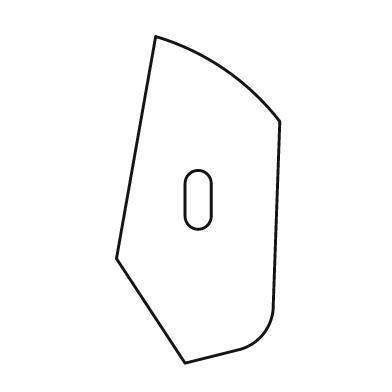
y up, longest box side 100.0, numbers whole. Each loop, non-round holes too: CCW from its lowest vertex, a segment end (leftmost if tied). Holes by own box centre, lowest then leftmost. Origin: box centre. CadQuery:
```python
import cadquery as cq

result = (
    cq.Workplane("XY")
    .moveTo(-4.0, -50.0)
    .lineTo(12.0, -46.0)
    .threePointArc((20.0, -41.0), (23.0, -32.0))
    .lineTo(25.0, 24.0)
    .threePointArc((8.0, 40.0), (-13.0, 50.0))
    .lineTo(-25.0, -18.0)
    .close()
    .moveTo(-4.0, -5.0)
    .threePointArc((0.0, -9.0), (4.0, -5.0))
    .lineTo(4.0, 5.0)
    .threePointArc((0.0, 9.0), (-4.0, 5.0))
    .close()
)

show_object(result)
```